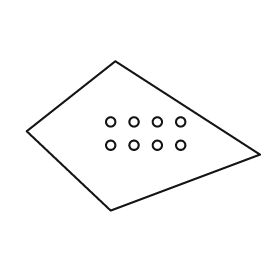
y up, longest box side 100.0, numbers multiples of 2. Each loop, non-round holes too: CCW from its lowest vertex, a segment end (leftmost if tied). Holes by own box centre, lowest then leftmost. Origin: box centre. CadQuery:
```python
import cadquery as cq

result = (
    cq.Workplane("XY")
    .moveTo(-14.0, -32.0)
    .lineTo(50.0, -8.0)
    .lineTo(-12.0, 32.0)
    .lineTo(-50.0, 2.0)
    .close()
    .moveTo(-14.0, -4.0)
    .circle(2.0)
    .moveTo(-4.0, -4.0)
    .circle(2.0)
    .moveTo(6.0, -4.0)
    .circle(2.0)
    .moveTo(16.0, -4.0)
    .circle(2.0)
    .moveTo(-14.0, 6.0)
    .circle(2.0)
    .moveTo(-4.0, 6.0)
    .circle(2.0)
    .moveTo(6.0, 6.0)
    .circle(2.0)
    .moveTo(16.0, 6.0)
    .circle(2.0)
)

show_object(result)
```